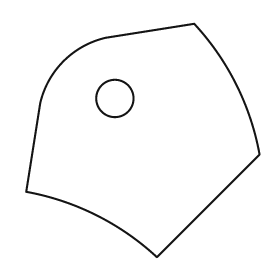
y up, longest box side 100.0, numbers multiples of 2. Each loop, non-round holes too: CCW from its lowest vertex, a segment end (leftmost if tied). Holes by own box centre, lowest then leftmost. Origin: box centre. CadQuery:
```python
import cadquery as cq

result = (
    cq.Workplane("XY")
    .moveTo(6.0, -50.0)
    .lineTo(50.0, -6.0)
    .threePointArc((40.0, 24.0), (22.0, 50.0))
    .lineTo(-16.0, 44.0)
    .threePointArc((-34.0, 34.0), (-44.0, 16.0))
    .lineTo(-50.0, -22.0)
    .threePointArc((-20.0, -32.0), (6.0, -50.0))
    .close()
    .moveTo(-12.0, 18.0)
    .circle(8.0)
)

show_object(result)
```